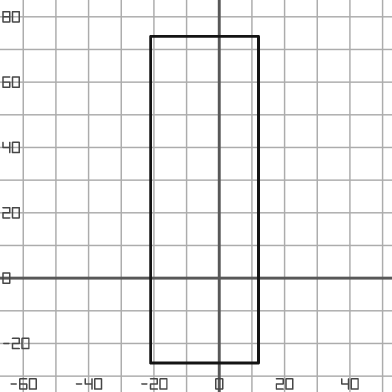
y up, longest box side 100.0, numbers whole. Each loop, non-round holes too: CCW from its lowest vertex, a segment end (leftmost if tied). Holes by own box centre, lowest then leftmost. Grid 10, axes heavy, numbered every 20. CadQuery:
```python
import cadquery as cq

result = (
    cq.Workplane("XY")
    .moveTo(-21.0, -26.0)
    .lineTo(12.0, -26.0)
    .lineTo(12.0, 74.0)
    .lineTo(-21.0, 74.0)
    .close()
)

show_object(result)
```